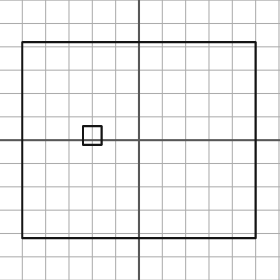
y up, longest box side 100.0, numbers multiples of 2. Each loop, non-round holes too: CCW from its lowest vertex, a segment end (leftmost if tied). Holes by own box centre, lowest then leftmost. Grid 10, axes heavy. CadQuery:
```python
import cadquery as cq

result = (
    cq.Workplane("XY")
    .moveTo(-50.0, -42.0)
    .lineTo(50.0, -42.0)
    .lineTo(50.0, 42.0)
    .lineTo(-50.0, 42.0)
    .close()
    .moveTo(-24.0, -2.0)
    .lineTo(-16.0, -2.0)
    .lineTo(-16.0, 6.0)
    .lineTo(-24.0, 6.0)
    .close()
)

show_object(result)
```